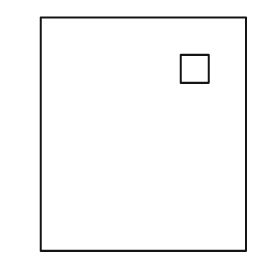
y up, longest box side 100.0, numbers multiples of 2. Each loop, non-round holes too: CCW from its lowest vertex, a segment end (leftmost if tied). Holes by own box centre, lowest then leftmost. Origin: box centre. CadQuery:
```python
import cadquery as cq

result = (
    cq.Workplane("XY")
    .moveTo(-44.0, -50.0)
    .lineTo(44.0, -50.0)
    .lineTo(44.0, 50.0)
    .lineTo(-44.0, 50.0)
    .close()
    .moveTo(16.0, 22.0)
    .lineTo(28.0, 22.0)
    .lineTo(28.0, 34.0)
    .lineTo(16.0, 34.0)
    .close()
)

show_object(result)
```